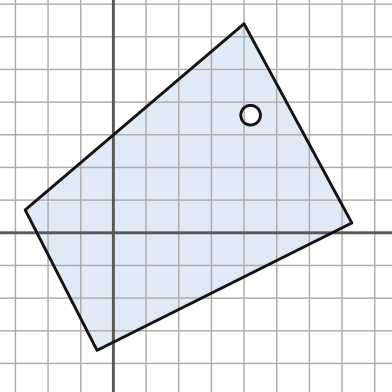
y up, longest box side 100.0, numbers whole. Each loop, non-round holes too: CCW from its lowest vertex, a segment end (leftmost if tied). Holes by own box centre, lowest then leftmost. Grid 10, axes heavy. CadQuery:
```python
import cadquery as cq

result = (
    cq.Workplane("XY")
    .moveTo(-5.0, -36.0)
    .lineTo(73.0, 3.0)
    .lineTo(40.0, 64.0)
    .lineTo(-27.0, 7.0)
    .close()
    .moveTo(42.0, 36.0)
    .circle(3.0)
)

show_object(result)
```